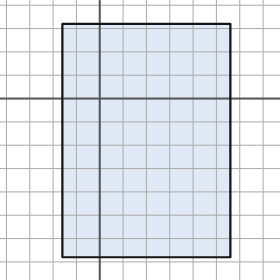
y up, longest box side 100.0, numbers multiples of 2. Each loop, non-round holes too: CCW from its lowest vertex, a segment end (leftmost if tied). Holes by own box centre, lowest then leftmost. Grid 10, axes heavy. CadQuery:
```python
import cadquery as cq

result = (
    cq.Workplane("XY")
    .moveTo(-16.0, -68.0)
    .lineTo(56.0, -68.0)
    .lineTo(56.0, 32.0)
    .lineTo(-16.0, 32.0)
    .close()
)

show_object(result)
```